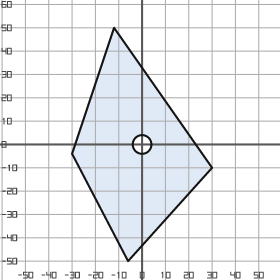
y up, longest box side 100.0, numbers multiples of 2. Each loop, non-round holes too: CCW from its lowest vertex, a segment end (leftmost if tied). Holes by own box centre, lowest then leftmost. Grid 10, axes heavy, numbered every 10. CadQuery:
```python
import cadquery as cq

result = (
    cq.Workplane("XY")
    .moveTo(-6.0, -50.0)
    .lineTo(30.0, -10.0)
    .lineTo(-12.0, 50.0)
    .lineTo(-30.0, -4.0)
    .close()
    .moveTo(0.0, 0.0)
    .circle(4.0)
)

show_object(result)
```